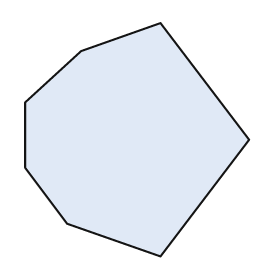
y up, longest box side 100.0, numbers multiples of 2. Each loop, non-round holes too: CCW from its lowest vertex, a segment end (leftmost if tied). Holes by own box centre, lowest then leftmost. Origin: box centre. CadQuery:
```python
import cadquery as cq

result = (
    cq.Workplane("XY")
    .moveTo(10.0, -50.0)
    .lineTo(48.0, 0.0)
    .lineTo(10.0, 50.0)
    .lineTo(-24.0, 38.0)
    .lineTo(-48.0, 16.0)
    .lineTo(-48.0, -12.0)
    .lineTo(-30.0, -36.0)
    .close()
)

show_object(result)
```